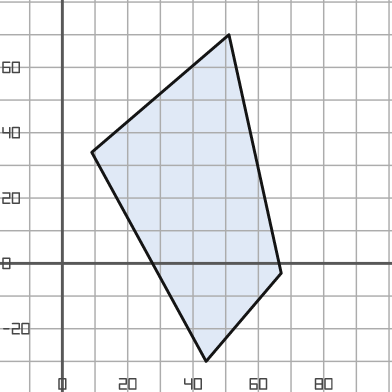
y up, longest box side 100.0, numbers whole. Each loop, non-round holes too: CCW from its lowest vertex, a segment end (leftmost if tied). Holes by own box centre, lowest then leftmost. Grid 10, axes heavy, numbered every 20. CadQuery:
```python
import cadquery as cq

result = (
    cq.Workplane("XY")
    .moveTo(44.0, -30.0)
    .lineTo(67.0, -3.0)
    .lineTo(51.0, 70.0)
    .lineTo(9.0, 34.0)
    .close()
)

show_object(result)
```